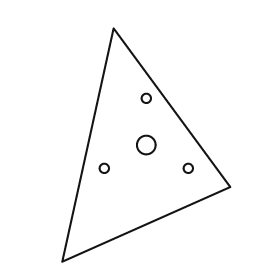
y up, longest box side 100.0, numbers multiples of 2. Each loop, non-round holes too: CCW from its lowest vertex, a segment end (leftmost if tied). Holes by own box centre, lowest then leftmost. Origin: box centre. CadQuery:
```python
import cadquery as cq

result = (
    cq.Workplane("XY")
    .moveTo(-36.0, -50.0)
    .lineTo(36.0, -18.0)
    .lineTo(-14.0, 50.0)
    .close()
    .moveTo(-18.0, -10.0)
    .circle(2.0)
    .moveTo(18.0, -10.0)
    .circle(2.0)
    .moveTo(0.0, 0.0)
    .circle(4.0)
    .moveTo(0.0, 20.0)
    .circle(2.0)
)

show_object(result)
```